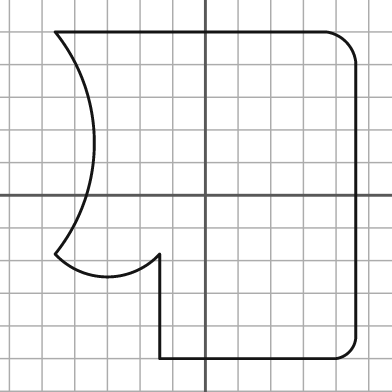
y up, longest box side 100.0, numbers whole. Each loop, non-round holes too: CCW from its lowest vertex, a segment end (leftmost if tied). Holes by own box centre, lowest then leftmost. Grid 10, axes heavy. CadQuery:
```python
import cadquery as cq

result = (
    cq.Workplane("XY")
    .moveTo(-14.0, -50.0)
    .lineTo(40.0, -50.0)
    .threePointArc((44.0, -48.0), (46.0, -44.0))
    .lineTo(46.0, 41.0)
    .threePointArc((43.0, 47.0), (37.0, 50.0))
    .lineTo(-46.0, 50.0)
    .threePointArc((-34.0, 16.0), (-46.0, -18.0))
    .threePointArc((-30.0, -25.0), (-14.0, -18.0))
    .close()
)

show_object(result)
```